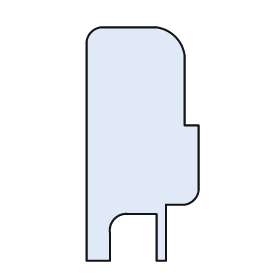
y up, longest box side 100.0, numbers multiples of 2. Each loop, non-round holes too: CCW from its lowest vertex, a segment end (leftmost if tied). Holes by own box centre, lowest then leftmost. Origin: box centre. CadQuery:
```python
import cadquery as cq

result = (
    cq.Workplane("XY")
    .moveTo(-24.0, -50.0)
    .lineTo(-14.0, -50.0)
    .lineTo(-14.0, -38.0)
    .threePointArc((-12.0, -32.0), (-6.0, -30.0))
    .lineTo(6.0, -30.0)
    .lineTo(6.0, -50.0)
    .lineTo(10.0, -50.0)
    .lineTo(10.0, -26.0)
    .lineTo(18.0, -26.0)
    .threePointArc((22.0, -24.0), (24.0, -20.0))
    .lineTo(24.0, 8.0)
    .lineTo(18.0, 8.0)
    .lineTo(18.0, 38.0)
    .threePointArc((14.0, 46.0), (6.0, 50.0))
    .lineTo(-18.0, 50.0)
    .threePointArc((-22.0, 48.0), (-24.0, 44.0))
    .close()
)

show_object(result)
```